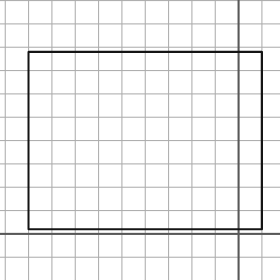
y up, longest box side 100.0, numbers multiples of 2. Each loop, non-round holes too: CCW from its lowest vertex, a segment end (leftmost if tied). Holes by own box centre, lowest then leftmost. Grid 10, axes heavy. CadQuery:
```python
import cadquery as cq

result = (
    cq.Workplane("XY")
    .moveTo(-90.0, 2.0)
    .lineTo(10.0, 2.0)
    .lineTo(10.0, 78.0)
    .lineTo(-90.0, 78.0)
    .close()
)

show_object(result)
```